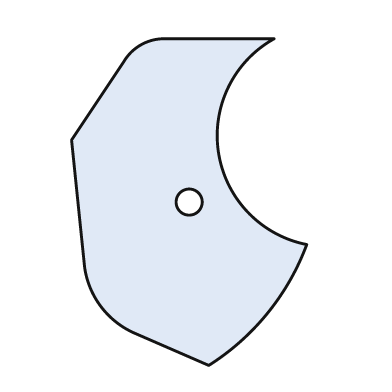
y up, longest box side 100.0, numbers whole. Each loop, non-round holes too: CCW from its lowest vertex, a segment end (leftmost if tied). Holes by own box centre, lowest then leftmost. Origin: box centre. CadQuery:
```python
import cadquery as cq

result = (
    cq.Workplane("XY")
    .moveTo(6.0, -50.0)
    .threePointArc((24.0, -34.0), (36.0, -13.0))
    .threePointArc((9.0, 15.0), (26.0, 50.0))
    .lineTo(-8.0, 50.0)
    .threePointArc((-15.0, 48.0), (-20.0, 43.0))
    .lineTo(-36.0, 19.0)
    .lineTo(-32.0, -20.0)
    .threePointArc((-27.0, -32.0), (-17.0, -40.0))
    .close()
    .moveTo(0.0, 0.0)
    .circle(4.0)
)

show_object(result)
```